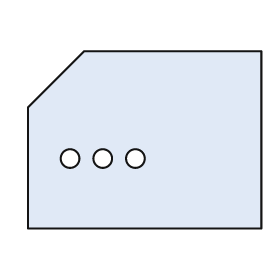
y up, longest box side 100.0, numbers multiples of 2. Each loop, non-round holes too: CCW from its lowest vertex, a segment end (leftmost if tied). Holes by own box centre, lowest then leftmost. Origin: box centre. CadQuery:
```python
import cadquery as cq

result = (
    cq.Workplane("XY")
    .moveTo(-50.0, -38.0)
    .lineTo(50.0, -38.0)
    .lineTo(50.0, 38.0)
    .lineTo(-26.0, 38.0)
    .lineTo(-50.0, 14.0)
    .close()
    .moveTo(-32.0, -8.0)
    .circle(4.0)
    .moveTo(-18.0, -8.0)
    .circle(4.0)
    .moveTo(-4.0, -8.0)
    .circle(4.0)
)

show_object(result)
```